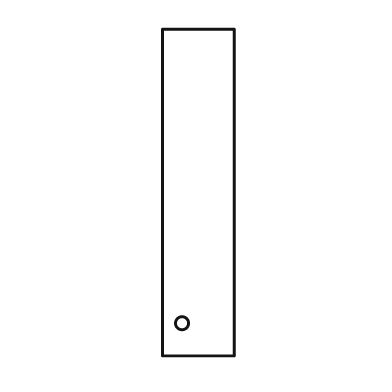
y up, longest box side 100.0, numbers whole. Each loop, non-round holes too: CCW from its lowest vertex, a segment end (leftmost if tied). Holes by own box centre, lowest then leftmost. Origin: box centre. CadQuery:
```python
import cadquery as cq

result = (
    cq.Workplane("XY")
    .moveTo(-11.0, -50.0)
    .lineTo(11.0, -50.0)
    .lineTo(11.0, 50.0)
    .lineTo(-11.0, 50.0)
    .close()
    .moveTo(-5.0, -40.0)
    .circle(2.0)
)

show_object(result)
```